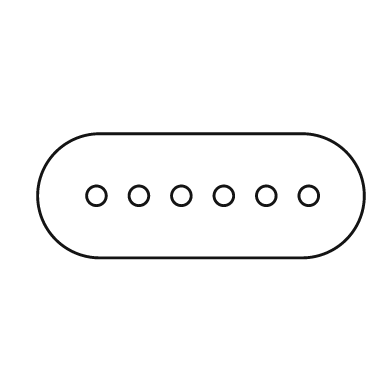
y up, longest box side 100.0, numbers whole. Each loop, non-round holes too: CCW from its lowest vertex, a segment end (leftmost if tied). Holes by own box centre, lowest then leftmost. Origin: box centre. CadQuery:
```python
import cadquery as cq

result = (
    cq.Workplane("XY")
    .moveTo(-31.0, -19.0)
    .lineTo(31.0, -19.0)
    .threePointArc((50.0, 0.0), (31.0, 19.0))
    .lineTo(-31.0, 19.0)
    .threePointArc((-50.0, 0.0), (-31.0, -19.0))
    .close()
    .moveTo(-32.0, 0.0)
    .circle(3.0)
    .moveTo(-19.0, 0.0)
    .circle(3.0)
    .moveTo(-6.0, 0.0)
    .circle(3.0)
    .moveTo(7.0, 0.0)
    .circle(3.0)
    .moveTo(20.0, 0.0)
    .circle(3.0)
    .moveTo(33.0, 0.0)
    .circle(3.0)
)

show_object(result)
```